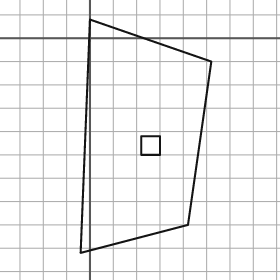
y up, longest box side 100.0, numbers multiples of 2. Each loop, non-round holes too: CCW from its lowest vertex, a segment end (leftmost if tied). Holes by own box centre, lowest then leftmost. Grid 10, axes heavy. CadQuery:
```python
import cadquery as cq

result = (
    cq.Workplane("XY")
    .moveTo(-4.0, -92.0)
    .lineTo(42.0, -80.0)
    .lineTo(52.0, -10.0)
    .lineTo(0.0, 8.0)
    .close()
    .moveTo(22.0, -50.0)
    .lineTo(30.0, -50.0)
    .lineTo(30.0, -42.0)
    .lineTo(22.0, -42.0)
    .close()
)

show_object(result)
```